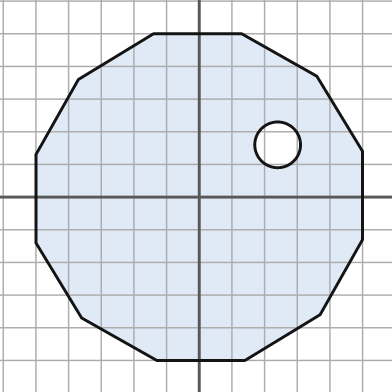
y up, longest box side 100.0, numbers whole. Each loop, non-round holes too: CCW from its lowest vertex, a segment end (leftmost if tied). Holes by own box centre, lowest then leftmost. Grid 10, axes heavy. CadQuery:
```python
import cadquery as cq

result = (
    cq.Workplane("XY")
    .moveTo(-13.0, -50.0)
    .lineTo(14.0, -50.0)
    .lineTo(37.0, -36.0)
    .lineTo(50.0, -13.0)
    .lineTo(50.0, 14.0)
    .lineTo(36.0, 37.0)
    .lineTo(13.0, 50.0)
    .lineTo(-14.0, 50.0)
    .lineTo(-37.0, 36.0)
    .lineTo(-50.0, 13.0)
    .lineTo(-50.0, -14.0)
    .lineTo(-36.0, -37.0)
    .close()
    .moveTo(24.0, 16.0)
    .circle(7.0)
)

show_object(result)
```